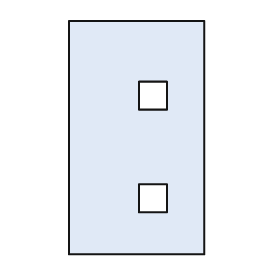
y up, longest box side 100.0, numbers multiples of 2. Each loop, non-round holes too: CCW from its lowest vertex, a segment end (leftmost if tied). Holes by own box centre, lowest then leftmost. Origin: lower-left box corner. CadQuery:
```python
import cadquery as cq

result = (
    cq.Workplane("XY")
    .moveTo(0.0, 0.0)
    .lineTo(58.0, 0.0)
    .lineTo(58.0, 100.0)
    .lineTo(0.0, 100.0)
    .close()
    .moveTo(30.0, 18.0)
    .lineTo(42.0, 18.0)
    .lineTo(42.0, 30.0)
    .lineTo(30.0, 30.0)
    .close()
    .moveTo(30.0, 62.0)
    .lineTo(42.0, 62.0)
    .lineTo(42.0, 74.0)
    .lineTo(30.0, 74.0)
    .close()
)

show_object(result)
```